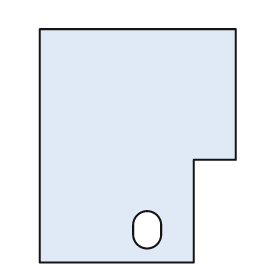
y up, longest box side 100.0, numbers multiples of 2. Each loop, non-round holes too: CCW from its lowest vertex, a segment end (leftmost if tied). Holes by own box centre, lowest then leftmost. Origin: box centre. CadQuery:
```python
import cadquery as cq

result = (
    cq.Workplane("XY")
    .moveTo(-42.0, -50.0)
    .lineTo(24.0, -50.0)
    .lineTo(24.0, -6.0)
    .lineTo(42.0, -6.0)
    .lineTo(42.0, 50.0)
    .lineTo(-42.0, 50.0)
    .close()
    .moveTo(-2.0, -38.0)
    .threePointArc((4.0, -44.0), (10.0, -38.0))
    .lineTo(10.0, -34.0)
    .threePointArc((4.0, -28.0), (-2.0, -34.0))
    .close()
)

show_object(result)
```